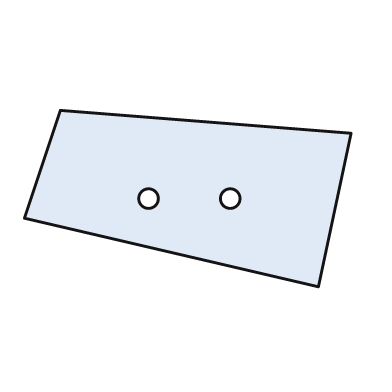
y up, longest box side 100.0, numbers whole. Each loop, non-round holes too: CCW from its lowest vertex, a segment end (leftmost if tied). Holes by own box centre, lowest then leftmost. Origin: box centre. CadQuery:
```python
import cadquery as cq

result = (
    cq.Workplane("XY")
    .moveTo(40.0, -27.0)
    .lineTo(50.0, 20.0)
    .lineTo(-39.0, 27.0)
    .lineTo(-50.0, -6.0)
    .close()
    .moveTo(-12.0, 0.0)
    .circle(3.0)
    .moveTo(13.0, 0.0)
    .circle(3.0)
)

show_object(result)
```